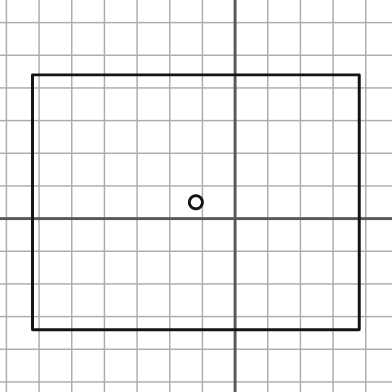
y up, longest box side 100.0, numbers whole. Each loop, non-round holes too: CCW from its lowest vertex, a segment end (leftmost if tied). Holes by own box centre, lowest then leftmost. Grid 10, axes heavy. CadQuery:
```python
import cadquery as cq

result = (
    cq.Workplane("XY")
    .moveTo(-62.0, -34.0)
    .lineTo(38.0, -34.0)
    .lineTo(38.0, 44.0)
    .lineTo(-62.0, 44.0)
    .close()
    .moveTo(-12.0, 5.0)
    .circle(2.0)
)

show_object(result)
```